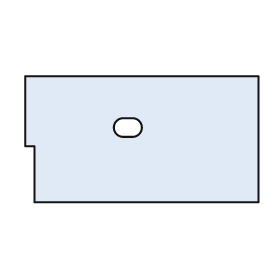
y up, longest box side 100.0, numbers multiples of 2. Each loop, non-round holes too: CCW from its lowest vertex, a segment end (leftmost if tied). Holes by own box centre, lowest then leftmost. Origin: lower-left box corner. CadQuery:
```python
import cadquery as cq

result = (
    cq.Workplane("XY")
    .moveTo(4.0, 0.0)
    .lineTo(100.0, 0.0)
    .lineTo(100.0, 54.0)
    .lineTo(0.0, 54.0)
    .lineTo(0.0, 24.0)
    .lineTo(4.0, 24.0)
    .close()
    .moveTo(42.0, 28.0)
    .lineTo(46.0, 28.0)
    .threePointArc((50.0, 32.0), (46.0, 36.0))
    .lineTo(42.0, 36.0)
    .threePointArc((38.0, 32.0), (42.0, 28.0))
    .close()
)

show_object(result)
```